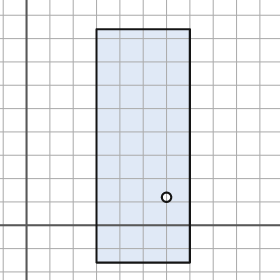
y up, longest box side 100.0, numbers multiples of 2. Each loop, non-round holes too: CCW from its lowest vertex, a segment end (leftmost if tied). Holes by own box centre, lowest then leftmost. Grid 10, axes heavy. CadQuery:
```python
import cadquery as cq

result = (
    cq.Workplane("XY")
    .moveTo(30.0, -16.0)
    .lineTo(70.0, -16.0)
    .lineTo(70.0, 84.0)
    .lineTo(30.0, 84.0)
    .close()
    .moveTo(60.0, 12.0)
    .circle(2.0)
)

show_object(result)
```